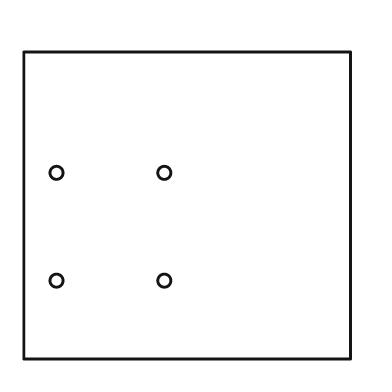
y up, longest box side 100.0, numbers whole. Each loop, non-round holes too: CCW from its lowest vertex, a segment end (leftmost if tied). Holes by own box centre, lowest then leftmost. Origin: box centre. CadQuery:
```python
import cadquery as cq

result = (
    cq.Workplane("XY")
    .moveTo(-50.0, -47.0)
    .lineTo(50.0, -47.0)
    .lineTo(50.0, 47.0)
    .lineTo(-50.0, 47.0)
    .close()
    .moveTo(-40.0, -23.0)
    .circle(2.0)
    .moveTo(-7.0, -23.0)
    .circle(2.0)
    .moveTo(-40.0, 10.0)
    .circle(2.0)
    .moveTo(-7.0, 10.0)
    .circle(2.0)
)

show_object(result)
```